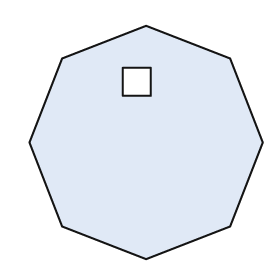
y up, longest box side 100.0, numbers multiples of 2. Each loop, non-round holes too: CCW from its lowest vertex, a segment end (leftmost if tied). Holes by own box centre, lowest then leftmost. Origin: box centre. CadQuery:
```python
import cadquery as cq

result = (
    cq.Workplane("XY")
    .moveTo(0.0, -50.0)
    .lineTo(36.0, -36.0)
    .lineTo(50.0, 0.0)
    .lineTo(36.0, 36.0)
    .lineTo(0.0, 50.0)
    .lineTo(-36.0, 36.0)
    .lineTo(-50.0, 0.0)
    .lineTo(-36.0, -36.0)
    .close()
    .moveTo(-10.0, 20.0)
    .lineTo(2.0, 20.0)
    .lineTo(2.0, 32.0)
    .lineTo(-10.0, 32.0)
    .close()
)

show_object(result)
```